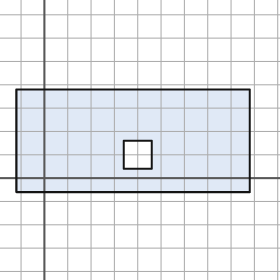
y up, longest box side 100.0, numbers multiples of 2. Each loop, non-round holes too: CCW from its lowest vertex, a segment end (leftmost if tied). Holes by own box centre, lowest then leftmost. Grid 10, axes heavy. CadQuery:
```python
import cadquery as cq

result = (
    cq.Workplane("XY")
    .moveTo(-12.0, -6.0)
    .lineTo(88.0, -6.0)
    .lineTo(88.0, 38.0)
    .lineTo(-12.0, 38.0)
    .close()
    .moveTo(34.0, 4.0)
    .lineTo(46.0, 4.0)
    .lineTo(46.0, 16.0)
    .lineTo(34.0, 16.0)
    .close()
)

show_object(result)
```